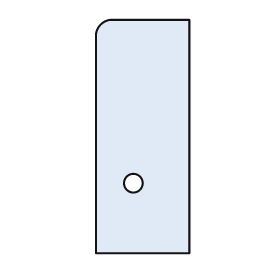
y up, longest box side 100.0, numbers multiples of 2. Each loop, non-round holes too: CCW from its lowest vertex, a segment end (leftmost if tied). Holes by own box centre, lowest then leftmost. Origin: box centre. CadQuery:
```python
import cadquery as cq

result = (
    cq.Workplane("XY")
    .moveTo(-20.0, -50.0)
    .lineTo(20.0, -50.0)
    .lineTo(20.0, 50.0)
    .lineTo(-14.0, 50.0)
    .threePointArc((-18.0, 48.0), (-20.0, 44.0))
    .close()
    .moveTo(-4.0, -20.0)
    .circle(4.0)
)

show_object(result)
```